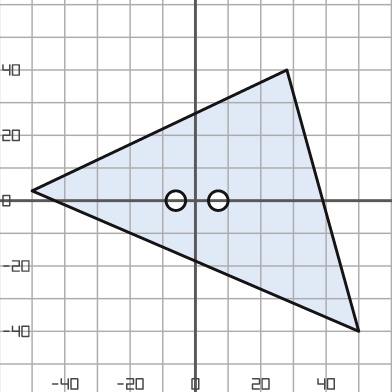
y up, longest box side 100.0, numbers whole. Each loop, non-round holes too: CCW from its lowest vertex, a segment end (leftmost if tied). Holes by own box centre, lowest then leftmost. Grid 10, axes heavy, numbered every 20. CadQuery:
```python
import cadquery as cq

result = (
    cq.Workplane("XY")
    .moveTo(50.0, -40.0)
    .lineTo(28.0, 40.0)
    .lineTo(-50.0, 3.0)
    .close()
    .moveTo(-6.0, 0.0)
    .circle(3.0)
    .moveTo(7.0, 0.0)
    .circle(3.0)
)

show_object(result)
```